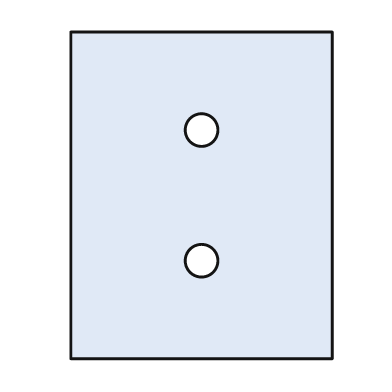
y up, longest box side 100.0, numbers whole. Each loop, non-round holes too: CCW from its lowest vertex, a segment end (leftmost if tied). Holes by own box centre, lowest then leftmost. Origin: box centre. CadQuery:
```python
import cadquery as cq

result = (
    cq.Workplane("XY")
    .moveTo(-40.0, -50.0)
    .lineTo(40.0, -50.0)
    .lineTo(40.0, 50.0)
    .lineTo(-40.0, 50.0)
    .close()
    .moveTo(0.0, -20.0)
    .circle(5.0)
    .moveTo(0.0, 20.0)
    .circle(5.0)
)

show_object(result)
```